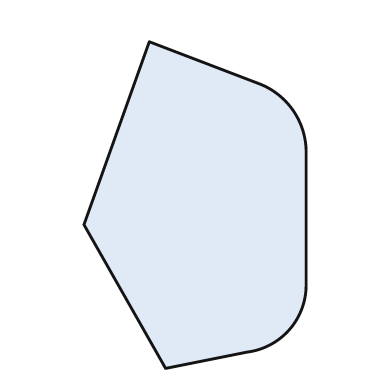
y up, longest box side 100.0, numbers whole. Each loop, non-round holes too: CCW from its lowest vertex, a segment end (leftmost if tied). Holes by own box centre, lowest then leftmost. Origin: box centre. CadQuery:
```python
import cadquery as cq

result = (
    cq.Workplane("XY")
    .moveTo(-9.0, -50.0)
    .lineTo(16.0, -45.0)
    .threePointArc((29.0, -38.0), (34.0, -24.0))
    .lineTo(34.0, 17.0)
    .threePointArc((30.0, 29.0), (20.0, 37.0))
    .lineTo(-14.0, 50.0)
    .lineTo(-34.0, -6.0)
    .close()
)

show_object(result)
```